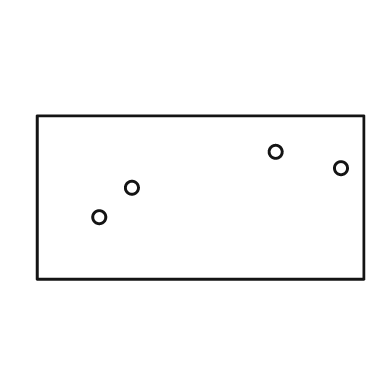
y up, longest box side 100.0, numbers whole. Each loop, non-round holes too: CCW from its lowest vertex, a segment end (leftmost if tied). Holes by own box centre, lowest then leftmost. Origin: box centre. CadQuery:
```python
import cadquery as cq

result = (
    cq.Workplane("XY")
    .moveTo(-50.0, -25.0)
    .lineTo(50.0, -25.0)
    .lineTo(50.0, 25.0)
    .lineTo(-50.0, 25.0)
    .close()
    .moveTo(-31.0, -6.0)
    .circle(2.0)
    .moveTo(-21.0, 3.0)
    .circle(2.0)
    .moveTo(43.0, 9.0)
    .circle(2.0)
    .moveTo(23.0, 14.0)
    .circle(2.0)
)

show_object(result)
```